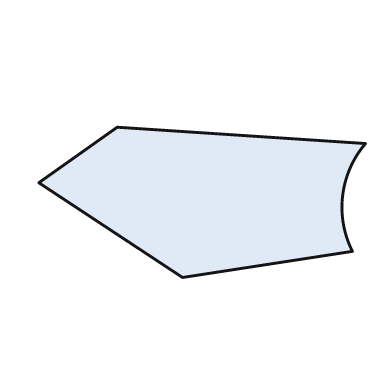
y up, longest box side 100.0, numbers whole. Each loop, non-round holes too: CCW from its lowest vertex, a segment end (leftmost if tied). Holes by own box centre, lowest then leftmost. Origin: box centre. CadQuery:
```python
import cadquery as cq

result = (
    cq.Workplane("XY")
    .moveTo(-6.0, -23.0)
    .lineTo(46.0, -15.0)
    .threePointArc((43.0, 2.0), (50.0, 18.0))
    .lineTo(-26.0, 23.0)
    .lineTo(-50.0, 6.0)
    .close()
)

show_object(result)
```